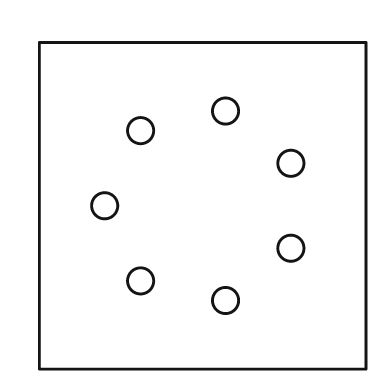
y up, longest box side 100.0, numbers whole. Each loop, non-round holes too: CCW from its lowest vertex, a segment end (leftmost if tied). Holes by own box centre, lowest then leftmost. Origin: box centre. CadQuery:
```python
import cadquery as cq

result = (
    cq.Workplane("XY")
    .moveTo(-50.0, -50.0)
    .lineTo(50.0, -50.0)
    .lineTo(50.0, 50.0)
    .lineTo(-50.0, 50.0)
    .close()
    .moveTo(7.0, -29.0)
    .circle(4.0)
    .moveTo(-19.0, -23.0)
    .circle(4.0)
    .moveTo(27.0, -13.0)
    .circle(4.0)
    .moveTo(-30.0, 0.0)
    .circle(4.0)
    .moveTo(27.0, 13.0)
    .circle(4.0)
    .moveTo(-19.0, 23.0)
    .circle(4.0)
    .moveTo(7.0, 29.0)
    .circle(4.0)
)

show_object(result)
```